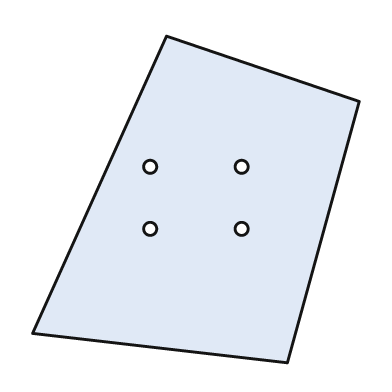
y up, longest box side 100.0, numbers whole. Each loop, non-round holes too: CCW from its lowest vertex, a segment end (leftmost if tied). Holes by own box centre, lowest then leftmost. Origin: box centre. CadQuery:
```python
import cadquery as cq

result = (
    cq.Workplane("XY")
    .moveTo(28.0, -50.0)
    .lineTo(50.0, 30.0)
    .lineTo(-9.0, 50.0)
    .lineTo(-50.0, -41.0)
    .close()
    .moveTo(-14.0, -9.0)
    .circle(2.0)
    .moveTo(14.0, -9.0)
    .circle(2.0)
    .moveTo(-14.0, 10.0)
    .circle(2.0)
    .moveTo(14.0, 10.0)
    .circle(2.0)
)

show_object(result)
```